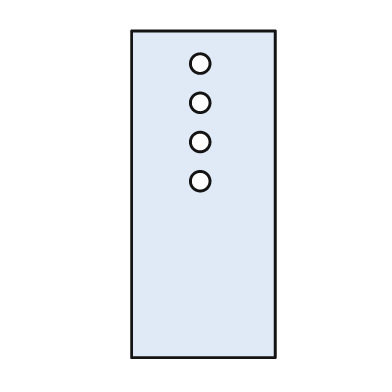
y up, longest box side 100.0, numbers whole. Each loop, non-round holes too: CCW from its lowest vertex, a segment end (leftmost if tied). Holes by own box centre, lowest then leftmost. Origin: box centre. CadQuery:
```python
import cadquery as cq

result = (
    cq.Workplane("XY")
    .moveTo(-22.0, -50.0)
    .lineTo(22.0, -50.0)
    .lineTo(22.0, 50.0)
    .lineTo(-22.0, 50.0)
    .close()
    .moveTo(-1.0, 4.0)
    .circle(3.0)
    .moveTo(-1.0, 16.0)
    .circle(3.0)
    .moveTo(-1.0, 28.0)
    .circle(3.0)
    .moveTo(-1.0, 40.0)
    .circle(3.0)
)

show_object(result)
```